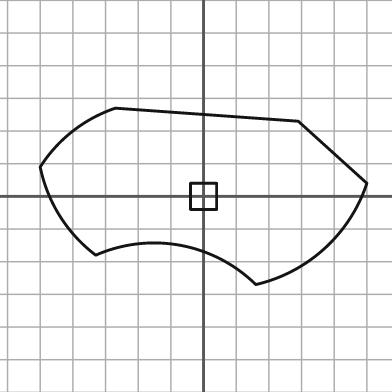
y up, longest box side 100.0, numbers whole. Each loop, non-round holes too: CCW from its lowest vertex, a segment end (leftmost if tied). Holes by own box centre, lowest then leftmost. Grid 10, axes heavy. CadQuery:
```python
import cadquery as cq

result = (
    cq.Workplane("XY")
    .moveTo(16.0, -27.0)
    .threePointArc((37.0, -16.0), (50.0, 4.0))
    .lineTo(29.0, 23.0)
    .lineTo(-27.0, 27.0)
    .threePointArc((-40.0, 20.0), (-50.0, 9.0))
    .threePointArc((-44.0, -6.0), (-33.0, -18.0))
    .threePointArc((-7.0, -15.0), (16.0, -27.0))
    .close()
    .moveTo(-4.0, -4.0)
    .lineTo(4.0, -4.0)
    .lineTo(4.0, 4.0)
    .lineTo(-4.0, 4.0)
    .close()
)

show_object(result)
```